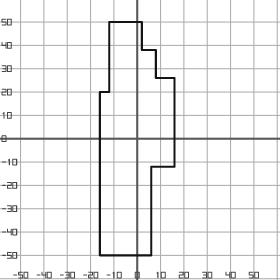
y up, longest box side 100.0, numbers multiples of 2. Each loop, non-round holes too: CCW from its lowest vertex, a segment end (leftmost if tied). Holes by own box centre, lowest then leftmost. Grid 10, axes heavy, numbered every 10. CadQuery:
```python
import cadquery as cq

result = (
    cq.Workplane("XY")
    .moveTo(-16.0, -50.0)
    .lineTo(6.0, -50.0)
    .lineTo(6.0, -12.0)
    .lineTo(16.0, -12.0)
    .lineTo(16.0, 26.0)
    .lineTo(8.0, 26.0)
    .lineTo(8.0, 38.0)
    .lineTo(2.0, 38.0)
    .lineTo(2.0, 50.0)
    .lineTo(-12.0, 50.0)
    .lineTo(-12.0, 20.0)
    .lineTo(-16.0, 20.0)
    .close()
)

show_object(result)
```